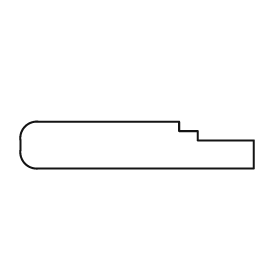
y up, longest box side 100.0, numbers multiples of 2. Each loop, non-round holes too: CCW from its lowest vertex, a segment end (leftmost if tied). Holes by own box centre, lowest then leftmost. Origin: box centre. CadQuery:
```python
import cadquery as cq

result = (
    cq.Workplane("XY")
    .moveTo(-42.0, -10.0)
    .lineTo(50.0, -10.0)
    .lineTo(50.0, 2.0)
    .lineTo(26.0, 2.0)
    .lineTo(26.0, 6.0)
    .lineTo(18.0, 6.0)
    .lineTo(18.0, 10.0)
    .lineTo(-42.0, 10.0)
    .threePointArc((-48.0, 8.0), (-50.0, 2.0))
    .lineTo(-50.0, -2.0)
    .threePointArc((-48.0, -8.0), (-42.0, -10.0))
    .close()
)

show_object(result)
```